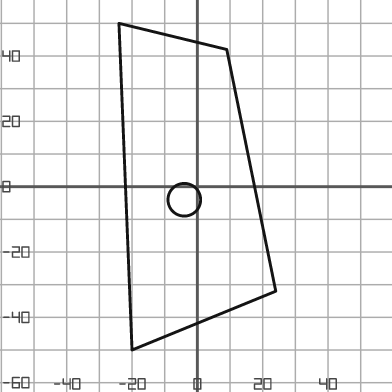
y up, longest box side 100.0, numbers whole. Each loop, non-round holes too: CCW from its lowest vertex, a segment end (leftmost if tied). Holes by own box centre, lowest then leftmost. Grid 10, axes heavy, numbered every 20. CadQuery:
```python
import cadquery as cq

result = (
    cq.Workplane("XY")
    .moveTo(-20.0, -50.0)
    .lineTo(24.0, -32.0)
    .lineTo(9.0, 42.0)
    .lineTo(-24.0, 50.0)
    .close()
    .moveTo(-4.0, -4.0)
    .circle(5.0)
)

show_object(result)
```